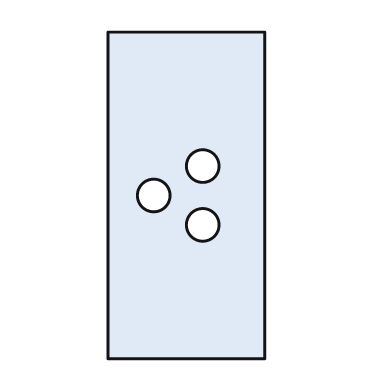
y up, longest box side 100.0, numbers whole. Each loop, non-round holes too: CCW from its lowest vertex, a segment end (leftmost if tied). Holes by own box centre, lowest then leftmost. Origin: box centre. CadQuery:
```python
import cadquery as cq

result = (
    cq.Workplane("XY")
    .moveTo(-24.0, -50.0)
    .lineTo(24.0, -50.0)
    .lineTo(24.0, 50.0)
    .lineTo(-24.0, 50.0)
    .close()
    .moveTo(5.0, -9.0)
    .circle(5.0)
    .moveTo(-10.0, 0.0)
    .circle(5.0)
    .moveTo(5.0, 9.0)
    .circle(5.0)
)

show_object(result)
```